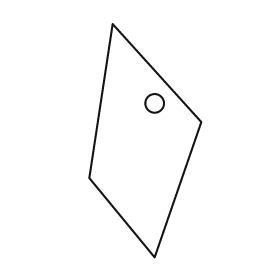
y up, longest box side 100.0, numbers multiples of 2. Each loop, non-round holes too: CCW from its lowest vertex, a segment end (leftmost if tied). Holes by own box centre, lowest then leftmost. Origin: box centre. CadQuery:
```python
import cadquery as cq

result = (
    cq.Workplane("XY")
    .moveTo(4.0, -50.0)
    .lineTo(24.0, 8.0)
    .lineTo(-14.0, 50.0)
    .lineTo(-24.0, -16.0)
    .close()
    .moveTo(4.0, 16.0)
    .circle(4.0)
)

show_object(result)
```